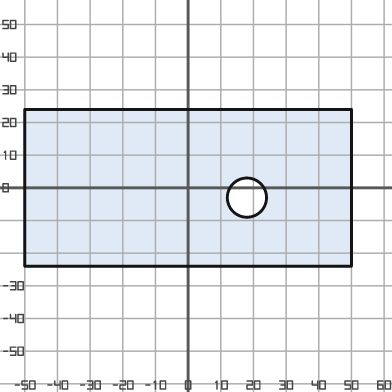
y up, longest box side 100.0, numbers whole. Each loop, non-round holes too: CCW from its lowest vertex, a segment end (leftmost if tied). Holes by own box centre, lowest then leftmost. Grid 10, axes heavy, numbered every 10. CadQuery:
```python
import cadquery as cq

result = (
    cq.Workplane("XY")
    .moveTo(-50.0, -24.0)
    .lineTo(50.0, -24.0)
    .lineTo(50.0, 24.0)
    .lineTo(-50.0, 24.0)
    .close()
    .moveTo(18.0, -3.0)
    .circle(6.0)
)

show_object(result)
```